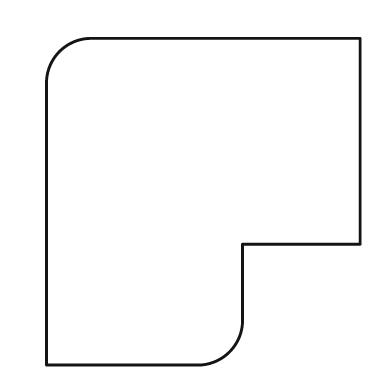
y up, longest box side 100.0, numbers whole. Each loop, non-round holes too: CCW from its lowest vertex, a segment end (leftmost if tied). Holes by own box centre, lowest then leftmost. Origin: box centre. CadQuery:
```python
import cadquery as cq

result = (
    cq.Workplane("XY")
    .moveTo(-48.0, -50.0)
    .lineTo(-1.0, -50.0)
    .threePointArc((8.0, -46.0), (12.0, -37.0))
    .lineTo(12.0, -13.0)
    .lineTo(48.0, -13.0)
    .lineTo(48.0, 50.0)
    .lineTo(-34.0, 50.0)
    .threePointArc((-44.0, 46.0), (-48.0, 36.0))
    .close()
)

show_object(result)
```